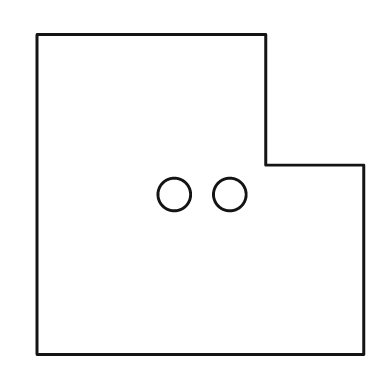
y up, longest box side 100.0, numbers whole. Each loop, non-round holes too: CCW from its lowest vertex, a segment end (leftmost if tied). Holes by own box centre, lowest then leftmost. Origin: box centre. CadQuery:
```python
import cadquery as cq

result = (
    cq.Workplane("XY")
    .moveTo(-50.0, -49.0)
    .lineTo(50.0, -49.0)
    .lineTo(50.0, 9.0)
    .lineTo(20.0, 9.0)
    .lineTo(20.0, 49.0)
    .lineTo(-50.0, 49.0)
    .close()
    .moveTo(-8.0, 0.0)
    .circle(5.0)
    .moveTo(9.0, 0.0)
    .circle(5.0)
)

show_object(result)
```